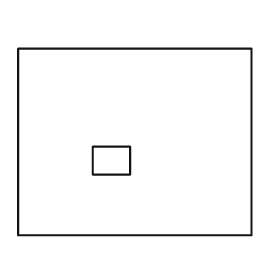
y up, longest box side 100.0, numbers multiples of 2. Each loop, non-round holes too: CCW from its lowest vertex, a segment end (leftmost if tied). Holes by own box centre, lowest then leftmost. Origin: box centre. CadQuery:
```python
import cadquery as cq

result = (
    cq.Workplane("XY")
    .moveTo(-50.0, -40.0)
    .lineTo(50.0, -40.0)
    .lineTo(50.0, 40.0)
    .lineTo(-50.0, 40.0)
    .close()
    .moveTo(-18.0, -14.0)
    .lineTo(-2.0, -14.0)
    .lineTo(-2.0, -2.0)
    .lineTo(-18.0, -2.0)
    .close()
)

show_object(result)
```